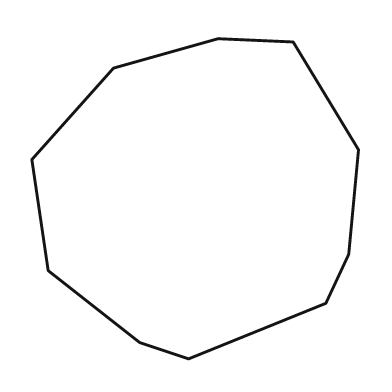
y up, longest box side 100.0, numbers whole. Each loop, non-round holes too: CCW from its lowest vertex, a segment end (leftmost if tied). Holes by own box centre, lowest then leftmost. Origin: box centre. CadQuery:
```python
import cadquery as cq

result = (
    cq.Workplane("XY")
    .moveTo(-2.0, -49.0)
    .lineTo(40.0, -32.0)
    .lineTo(47.0, -17.0)
    .lineTo(50.0, 15.0)
    .lineTo(30.0, 48.0)
    .lineTo(7.0, 49.0)
    .lineTo(-25.0, 40.0)
    .lineTo(-50.0, 12.0)
    .lineTo(-45.0, -22.0)
    .lineTo(-17.0, -44.0)
    .close()
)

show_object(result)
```